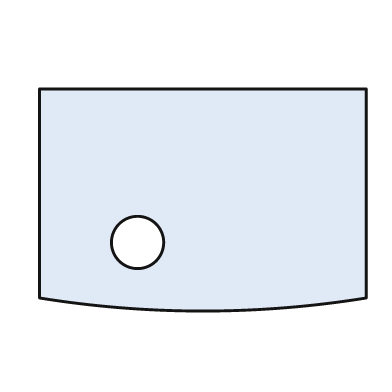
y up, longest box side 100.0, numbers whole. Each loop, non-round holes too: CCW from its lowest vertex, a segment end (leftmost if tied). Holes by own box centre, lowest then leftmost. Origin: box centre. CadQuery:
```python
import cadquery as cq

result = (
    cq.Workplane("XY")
    .moveTo(-50.0, -30.0)
    .threePointArc((0.0, -34.0), (50.0, -30.0))
    .lineTo(50.0, 34.0)
    .lineTo(-50.0, 34.0)
    .close()
    .moveTo(-20.0, -13.0)
    .circle(8.0)
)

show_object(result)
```